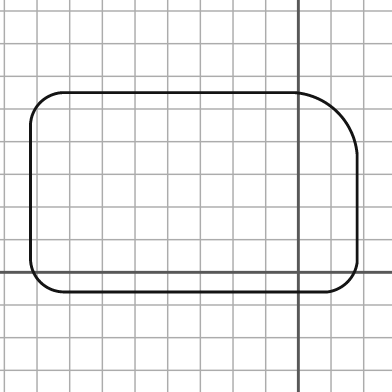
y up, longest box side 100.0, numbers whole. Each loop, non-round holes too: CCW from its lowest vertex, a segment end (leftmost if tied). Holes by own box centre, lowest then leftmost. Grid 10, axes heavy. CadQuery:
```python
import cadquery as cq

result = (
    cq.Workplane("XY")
    .moveTo(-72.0, -6.0)
    .lineTo(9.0, -6.0)
    .threePointArc((15.0, -3.0), (18.0, 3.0))
    .lineTo(18.0, 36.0)
    .threePointArc((12.0, 49.0), (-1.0, 55.0))
    .lineTo(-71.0, 55.0)
    .threePointArc((-79.0, 52.0), (-82.0, 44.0))
    .lineTo(-82.0, 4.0)
    .threePointArc((-79.0, -3.0), (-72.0, -6.0))
    .close()
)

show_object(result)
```